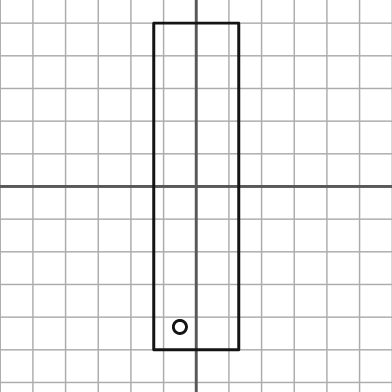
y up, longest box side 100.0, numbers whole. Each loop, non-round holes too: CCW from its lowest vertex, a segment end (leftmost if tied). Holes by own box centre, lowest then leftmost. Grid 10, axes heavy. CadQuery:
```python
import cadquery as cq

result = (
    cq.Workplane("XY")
    .moveTo(-13.0, -50.0)
    .lineTo(13.0, -50.0)
    .lineTo(13.0, 50.0)
    .lineTo(-13.0, 50.0)
    .close()
    .moveTo(-5.0, -43.0)
    .circle(2.0)
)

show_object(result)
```